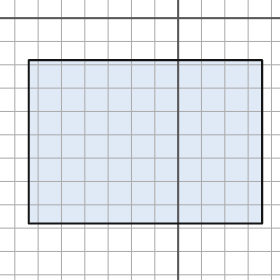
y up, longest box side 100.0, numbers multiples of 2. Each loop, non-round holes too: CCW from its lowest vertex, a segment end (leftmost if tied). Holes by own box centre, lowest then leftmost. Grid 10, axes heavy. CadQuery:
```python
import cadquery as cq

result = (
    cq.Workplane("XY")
    .moveTo(-64.0, -88.0)
    .lineTo(36.0, -88.0)
    .lineTo(36.0, -18.0)
    .lineTo(-64.0, -18.0)
    .close()
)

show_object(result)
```